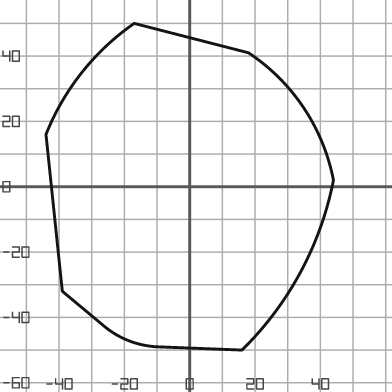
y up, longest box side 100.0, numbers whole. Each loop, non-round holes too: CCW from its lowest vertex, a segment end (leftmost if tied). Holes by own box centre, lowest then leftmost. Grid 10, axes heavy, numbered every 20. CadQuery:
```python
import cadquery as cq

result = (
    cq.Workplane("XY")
    .moveTo(16.0, -50.0)
    .threePointArc((34.0, -26.0), (44.0, 2.0))
    .threePointArc((35.0, 24.0), (18.0, 41.0))
    .lineTo(-17.0, 50.0)
    .threePointArc((-33.0, 35.0), (-44.0, 16.0))
    .lineTo(-39.0, -32.0)
    .lineTo(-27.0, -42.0)
    .threePointArc((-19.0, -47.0), (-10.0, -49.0))
    .close()
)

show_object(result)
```